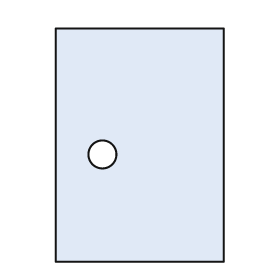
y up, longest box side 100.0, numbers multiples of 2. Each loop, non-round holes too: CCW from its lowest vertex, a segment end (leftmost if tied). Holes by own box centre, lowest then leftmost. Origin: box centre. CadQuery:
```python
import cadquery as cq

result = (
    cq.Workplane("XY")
    .moveTo(-36.0, -50.0)
    .lineTo(36.0, -50.0)
    .lineTo(36.0, 50.0)
    .lineTo(-36.0, 50.0)
    .close()
    .moveTo(-16.0, -4.0)
    .circle(6.0)
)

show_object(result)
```